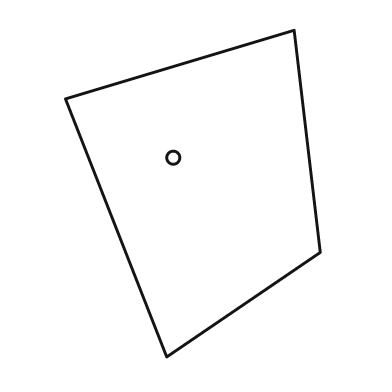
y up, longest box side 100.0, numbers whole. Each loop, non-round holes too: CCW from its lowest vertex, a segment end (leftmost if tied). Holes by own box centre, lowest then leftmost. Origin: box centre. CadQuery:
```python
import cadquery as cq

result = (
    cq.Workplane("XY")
    .moveTo(-8.0, -50.0)
    .lineTo(39.0, -18.0)
    .lineTo(31.0, 50.0)
    .lineTo(-39.0, 29.0)
    .close()
    .moveTo(-6.0, 11.0)
    .circle(2.0)
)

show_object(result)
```